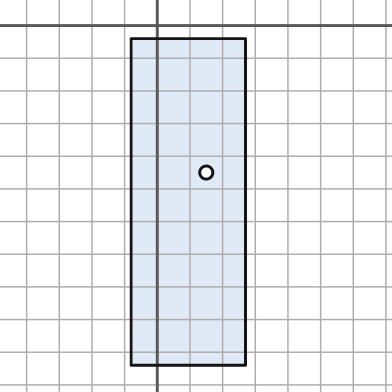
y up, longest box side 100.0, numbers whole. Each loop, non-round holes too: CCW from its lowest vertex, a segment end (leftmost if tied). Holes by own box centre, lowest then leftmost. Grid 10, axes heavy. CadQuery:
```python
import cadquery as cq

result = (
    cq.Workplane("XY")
    .moveTo(-8.0, -104.0)
    .lineTo(27.0, -104.0)
    .lineTo(27.0, -4.0)
    .lineTo(-8.0, -4.0)
    .close()
    .moveTo(15.0, -45.0)
    .circle(2.0)
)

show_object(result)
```